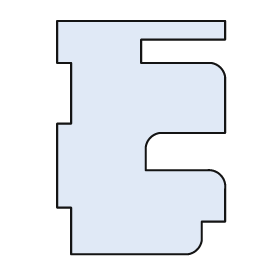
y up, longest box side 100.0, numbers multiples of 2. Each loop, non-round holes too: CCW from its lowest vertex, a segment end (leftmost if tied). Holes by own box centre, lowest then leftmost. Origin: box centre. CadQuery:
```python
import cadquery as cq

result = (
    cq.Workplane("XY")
    .moveTo(-30.0, -50.0)
    .lineTo(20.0, -50.0)
    .threePointArc((24.0, -48.0), (26.0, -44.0))
    .lineTo(26.0, -36.0)
    .lineTo(36.0, -36.0)
    .lineTo(36.0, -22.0)
    .threePointArc((34.0, -16.0), (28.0, -14.0))
    .lineTo(2.0, -14.0)
    .lineTo(2.0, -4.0)
    .threePointArc((4.0, 0.0), (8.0, 2.0))
    .lineTo(36.0, 2.0)
    .lineTo(36.0, 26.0)
    .threePointArc((34.0, 30.0), (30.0, 32.0))
    .lineTo(0.0, 32.0)
    .lineTo(0.0, 42.0)
    .lineTo(36.0, 42.0)
    .lineTo(36.0, 50.0)
    .lineTo(-36.0, 50.0)
    .lineTo(-36.0, 32.0)
    .lineTo(-30.0, 32.0)
    .lineTo(-30.0, 6.0)
    .lineTo(-36.0, 6.0)
    .lineTo(-36.0, -30.0)
    .lineTo(-30.0, -30.0)
    .close()
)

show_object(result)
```